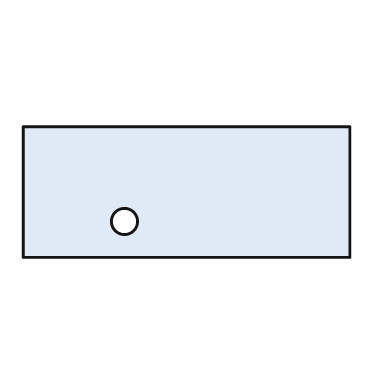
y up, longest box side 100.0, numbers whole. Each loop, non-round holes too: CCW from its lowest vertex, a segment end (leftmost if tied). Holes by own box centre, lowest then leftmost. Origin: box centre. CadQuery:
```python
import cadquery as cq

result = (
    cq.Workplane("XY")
    .moveTo(-50.0, -20.0)
    .lineTo(50.0, -20.0)
    .lineTo(50.0, 20.0)
    .lineTo(-50.0, 20.0)
    .close()
    .moveTo(-19.0, -9.0)
    .circle(4.0)
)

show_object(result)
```